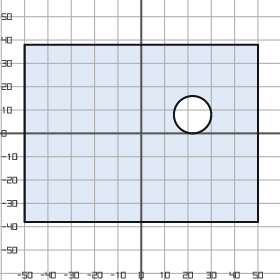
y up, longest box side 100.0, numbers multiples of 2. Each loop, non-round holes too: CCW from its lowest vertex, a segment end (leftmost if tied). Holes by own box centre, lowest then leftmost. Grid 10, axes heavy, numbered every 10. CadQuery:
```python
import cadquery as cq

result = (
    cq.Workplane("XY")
    .moveTo(-50.0, -38.0)
    .lineTo(50.0, -38.0)
    .lineTo(50.0, 38.0)
    .lineTo(-50.0, 38.0)
    .close()
    .moveTo(22.0, 8.0)
    .circle(8.0)
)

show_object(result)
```